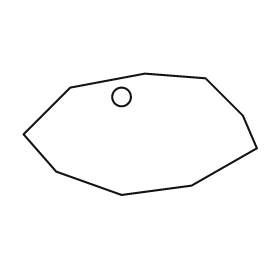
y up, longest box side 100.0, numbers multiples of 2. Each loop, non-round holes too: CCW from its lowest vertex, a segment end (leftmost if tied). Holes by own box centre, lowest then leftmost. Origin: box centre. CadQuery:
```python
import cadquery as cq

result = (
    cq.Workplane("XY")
    .moveTo(-8.0, -26.0)
    .lineTo(22.0, -22.0)
    .lineTo(50.0, -6.0)
    .lineTo(44.0, 8.0)
    .lineTo(28.0, 24.0)
    .lineTo(2.0, 26.0)
    .lineTo(-30.0, 20.0)
    .lineTo(-50.0, 0.0)
    .lineTo(-36.0, -16.0)
    .close()
    .moveTo(-8.0, 16.0)
    .circle(4.0)
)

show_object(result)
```